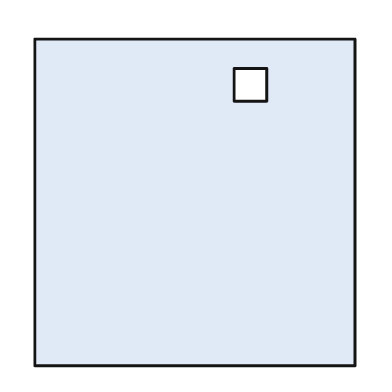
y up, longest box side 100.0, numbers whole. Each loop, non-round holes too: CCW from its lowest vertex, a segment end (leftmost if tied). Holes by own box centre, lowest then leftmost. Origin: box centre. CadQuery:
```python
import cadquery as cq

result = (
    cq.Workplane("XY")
    .moveTo(-49.0, -50.0)
    .lineTo(49.0, -50.0)
    .lineTo(49.0, 50.0)
    .lineTo(-49.0, 50.0)
    .close()
    .moveTo(12.0, 31.0)
    .lineTo(22.0, 31.0)
    .lineTo(22.0, 41.0)
    .lineTo(12.0, 41.0)
    .close()
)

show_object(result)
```